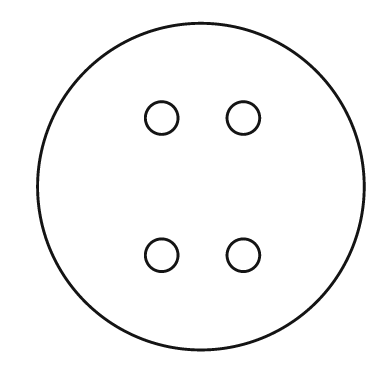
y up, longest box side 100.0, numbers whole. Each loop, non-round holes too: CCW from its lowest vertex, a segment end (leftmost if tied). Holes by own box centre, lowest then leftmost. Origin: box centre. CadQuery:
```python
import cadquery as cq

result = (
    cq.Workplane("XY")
    .moveTo(0.0, 0.0)
    .circle(50.0)
    .moveTo(-12.0, -21.0)
    .circle(5.0)
    .moveTo(13.0, -21.0)
    .circle(5.0)
    .moveTo(-12.0, 21.0)
    .circle(5.0)
    .moveTo(13.0, 21.0)
    .circle(5.0)
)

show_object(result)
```